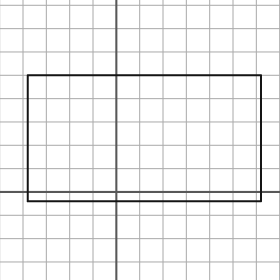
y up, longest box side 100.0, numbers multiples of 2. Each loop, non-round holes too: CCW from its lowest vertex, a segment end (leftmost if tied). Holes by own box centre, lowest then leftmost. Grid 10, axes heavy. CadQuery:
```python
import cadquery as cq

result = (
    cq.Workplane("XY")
    .moveTo(-38.0, -4.0)
    .lineTo(62.0, -4.0)
    .lineTo(62.0, 50.0)
    .lineTo(-38.0, 50.0)
    .close()
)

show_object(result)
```